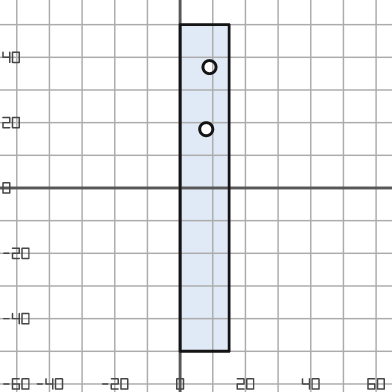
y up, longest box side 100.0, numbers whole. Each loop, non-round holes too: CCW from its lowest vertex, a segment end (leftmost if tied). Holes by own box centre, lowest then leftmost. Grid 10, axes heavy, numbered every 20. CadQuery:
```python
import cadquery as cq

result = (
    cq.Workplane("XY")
    .moveTo(0.0, -50.0)
    .lineTo(15.0, -50.0)
    .lineTo(15.0, 50.0)
    .lineTo(0.0, 50.0)
    .close()
    .moveTo(8.0, 18.0)
    .circle(2.0)
    .moveTo(9.0, 37.0)
    .circle(2.0)
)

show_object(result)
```